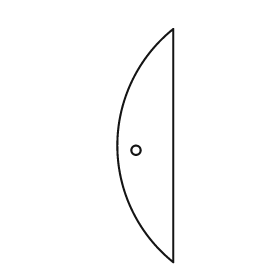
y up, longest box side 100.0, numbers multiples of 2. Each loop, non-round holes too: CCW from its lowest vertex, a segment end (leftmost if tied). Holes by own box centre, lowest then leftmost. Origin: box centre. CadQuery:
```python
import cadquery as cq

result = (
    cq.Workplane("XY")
    .moveTo(12.0, -50.0)
    .lineTo(12.0, 50.0)
    .threePointArc((-12.0, 0.0), (12.0, -50.0))
    .close()
    .moveTo(-4.0, -2.0)
    .circle(2.0)
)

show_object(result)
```